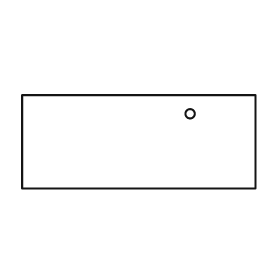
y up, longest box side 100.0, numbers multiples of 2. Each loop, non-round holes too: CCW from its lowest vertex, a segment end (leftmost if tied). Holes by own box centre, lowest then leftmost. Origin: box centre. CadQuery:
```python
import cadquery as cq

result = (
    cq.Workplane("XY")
    .moveTo(-50.0, -20.0)
    .lineTo(50.0, -20.0)
    .lineTo(50.0, 20.0)
    .lineTo(-50.0, 20.0)
    .close()
    .moveTo(22.0, 12.0)
    .circle(2.0)
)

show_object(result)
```